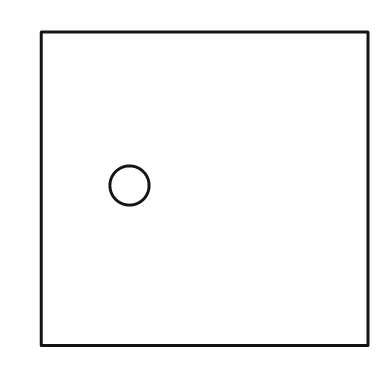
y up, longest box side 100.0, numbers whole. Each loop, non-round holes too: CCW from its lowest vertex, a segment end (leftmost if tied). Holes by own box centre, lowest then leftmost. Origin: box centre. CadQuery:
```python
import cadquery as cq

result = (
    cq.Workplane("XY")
    .moveTo(-50.0, -48.0)
    .lineTo(50.0, -48.0)
    .lineTo(50.0, 48.0)
    .lineTo(-50.0, 48.0)
    .close()
    .moveTo(-23.0, 1.0)
    .circle(6.0)
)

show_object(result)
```